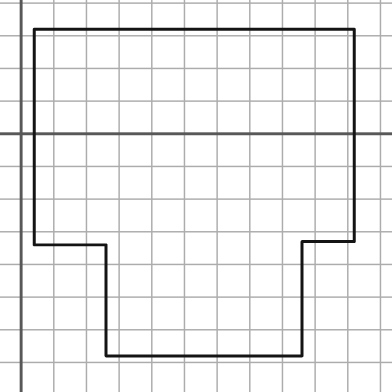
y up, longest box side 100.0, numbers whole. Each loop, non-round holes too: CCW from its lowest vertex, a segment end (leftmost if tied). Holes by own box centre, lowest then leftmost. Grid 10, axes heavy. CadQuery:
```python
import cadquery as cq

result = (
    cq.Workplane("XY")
    .moveTo(26.0, -68.0)
    .lineTo(86.0, -68.0)
    .lineTo(86.0, -33.0)
    .lineTo(102.0, -33.0)
    .lineTo(102.0, 32.0)
    .lineTo(4.0, 32.0)
    .lineTo(4.0, -34.0)
    .lineTo(26.0, -34.0)
    .close()
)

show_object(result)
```